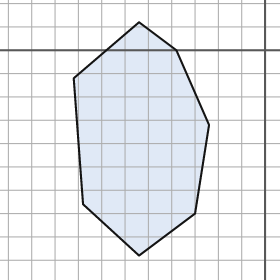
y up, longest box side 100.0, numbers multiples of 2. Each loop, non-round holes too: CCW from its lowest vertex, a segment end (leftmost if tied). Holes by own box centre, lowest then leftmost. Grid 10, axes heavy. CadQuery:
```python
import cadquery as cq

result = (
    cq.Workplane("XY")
    .moveTo(-54.0, -88.0)
    .lineTo(-30.0, -70.0)
    .lineTo(-24.0, -32.0)
    .lineTo(-38.0, 0.0)
    .lineTo(-54.0, 12.0)
    .lineTo(-82.0, -12.0)
    .lineTo(-78.0, -66.0)
    .close()
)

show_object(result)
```